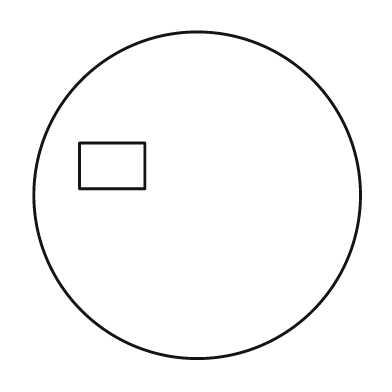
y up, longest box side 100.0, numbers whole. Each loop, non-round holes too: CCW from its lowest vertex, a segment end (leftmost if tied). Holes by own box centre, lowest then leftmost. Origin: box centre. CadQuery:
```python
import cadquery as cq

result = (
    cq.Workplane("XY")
    .moveTo(0.0, 0.0)
    .circle(50.0)
    .moveTo(-36.0, 2.0)
    .lineTo(-16.0, 2.0)
    .lineTo(-16.0, 16.0)
    .lineTo(-36.0, 16.0)
    .close()
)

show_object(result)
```